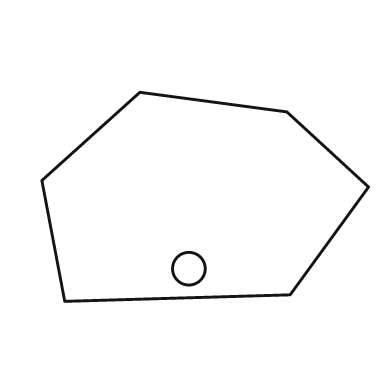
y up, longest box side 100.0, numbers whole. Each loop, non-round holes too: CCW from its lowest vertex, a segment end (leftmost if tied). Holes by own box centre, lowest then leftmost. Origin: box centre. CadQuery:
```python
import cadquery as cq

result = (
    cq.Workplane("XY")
    .moveTo(-43.0, -32.0)
    .lineTo(26.0, -30.0)
    .lineTo(50.0, 3.0)
    .lineTo(25.0, 26.0)
    .lineTo(-20.0, 32.0)
    .lineTo(-50.0, 5.0)
    .close()
    .moveTo(-5.0, -22.0)
    .circle(5.0)
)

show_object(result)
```